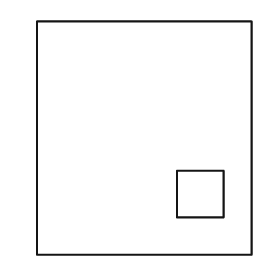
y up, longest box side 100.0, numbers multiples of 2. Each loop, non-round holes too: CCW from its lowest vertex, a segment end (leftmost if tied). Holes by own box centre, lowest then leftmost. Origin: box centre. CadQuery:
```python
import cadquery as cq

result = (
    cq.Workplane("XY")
    .moveTo(-46.0, -50.0)
    .lineTo(46.0, -50.0)
    .lineTo(46.0, 50.0)
    .lineTo(-46.0, 50.0)
    .close()
    .moveTo(14.0, -34.0)
    .lineTo(34.0, -34.0)
    .lineTo(34.0, -14.0)
    .lineTo(14.0, -14.0)
    .close()
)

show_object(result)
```